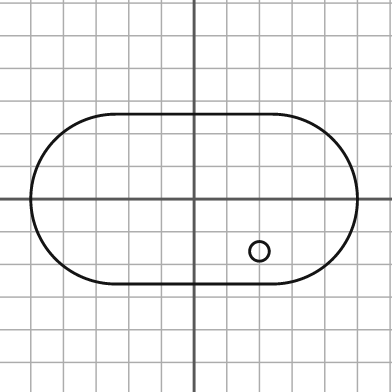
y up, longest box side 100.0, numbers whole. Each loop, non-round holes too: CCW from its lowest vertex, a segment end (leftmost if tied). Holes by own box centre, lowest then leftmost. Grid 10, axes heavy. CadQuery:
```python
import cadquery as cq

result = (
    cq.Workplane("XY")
    .moveTo(-24.0, -26.0)
    .lineTo(24.0, -26.0)
    .threePointArc((50.0, 0.0), (24.0, 26.0))
    .lineTo(-24.0, 26.0)
    .threePointArc((-50.0, 0.0), (-24.0, -26.0))
    .close()
    .moveTo(20.0, -16.0)
    .circle(3.0)
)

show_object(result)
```